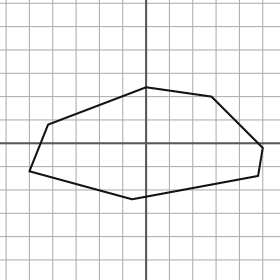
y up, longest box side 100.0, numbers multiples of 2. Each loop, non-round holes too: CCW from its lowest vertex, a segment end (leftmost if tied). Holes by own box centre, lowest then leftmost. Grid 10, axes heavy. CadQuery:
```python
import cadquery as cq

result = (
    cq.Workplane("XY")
    .moveTo(-6.0, -24.0)
    .lineTo(48.0, -14.0)
    .lineTo(50.0, -2.0)
    .lineTo(28.0, 20.0)
    .lineTo(0.0, 24.0)
    .lineTo(-42.0, 8.0)
    .lineTo(-50.0, -12.0)
    .close()
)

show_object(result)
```